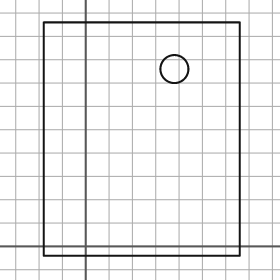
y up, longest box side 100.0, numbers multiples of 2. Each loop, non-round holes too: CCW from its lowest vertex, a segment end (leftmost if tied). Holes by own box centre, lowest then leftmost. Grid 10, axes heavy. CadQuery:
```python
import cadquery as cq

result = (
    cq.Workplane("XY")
    .moveTo(-18.0, -4.0)
    .lineTo(66.0, -4.0)
    .lineTo(66.0, 96.0)
    .lineTo(-18.0, 96.0)
    .close()
    .moveTo(38.0, 76.0)
    .circle(6.0)
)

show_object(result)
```